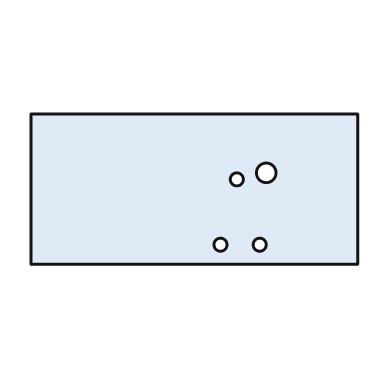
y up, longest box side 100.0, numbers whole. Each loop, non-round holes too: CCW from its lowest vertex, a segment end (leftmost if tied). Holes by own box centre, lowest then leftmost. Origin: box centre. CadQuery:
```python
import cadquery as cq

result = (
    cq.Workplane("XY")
    .moveTo(-50.0, -23.0)
    .lineTo(50.0, -23.0)
    .lineTo(50.0, 23.0)
    .lineTo(-50.0, 23.0)
    .close()
    .moveTo(8.0, -17.0)
    .circle(2.0)
    .moveTo(20.0, -17.0)
    .circle(2.0)
    .moveTo(13.0, 3.0)
    .circle(2.0)
    .moveTo(22.0, 5.0)
    .circle(3.0)
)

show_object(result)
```